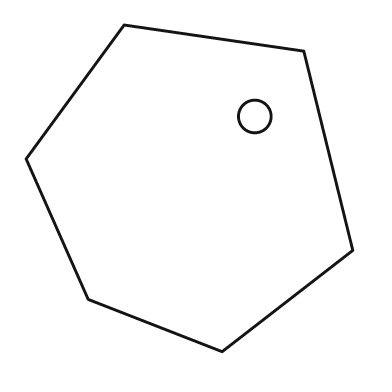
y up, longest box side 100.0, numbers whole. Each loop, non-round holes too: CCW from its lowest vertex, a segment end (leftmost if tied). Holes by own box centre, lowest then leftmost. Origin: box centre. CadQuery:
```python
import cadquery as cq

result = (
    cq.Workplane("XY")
    .moveTo(10.0, -50.0)
    .lineTo(50.0, -19.0)
    .lineTo(35.0, 42.0)
    .lineTo(-20.0, 50.0)
    .lineTo(-50.0, 9.0)
    .lineTo(-31.0, -34.0)
    .close()
    .moveTo(20.0, 22.0)
    .circle(5.0)
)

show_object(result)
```